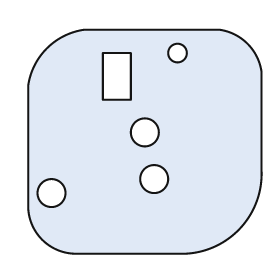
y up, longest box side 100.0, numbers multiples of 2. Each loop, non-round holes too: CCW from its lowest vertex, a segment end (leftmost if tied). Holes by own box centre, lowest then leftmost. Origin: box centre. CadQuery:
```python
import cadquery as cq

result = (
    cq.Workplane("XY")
    .moveTo(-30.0, -48.0)
    .lineTo(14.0, -48.0)
    .threePointArc((40.0, -38.0), (50.0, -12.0))
    .lineTo(50.0, 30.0)
    .threePointArc((44.0, 42.0), (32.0, 48.0))
    .lineTo(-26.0, 48.0)
    .threePointArc((-42.0, 40.0), (-50.0, 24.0))
    .lineTo(-50.0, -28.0)
    .threePointArc((-44.0, -42.0), (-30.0, -48.0))
    .close()
    .moveTo(-40.0, -22.0)
    .circle(6.0)
    .moveTo(4.0, -16.0)
    .circle(6.0)
    .moveTo(0.0, 4.0)
    .circle(6.0)
    .moveTo(-18.0, 18.0)
    .lineTo(-6.0, 18.0)
    .lineTo(-6.0, 38.0)
    .lineTo(-18.0, 38.0)
    .close()
    .moveTo(14.0, 38.0)
    .circle(4.0)
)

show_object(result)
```